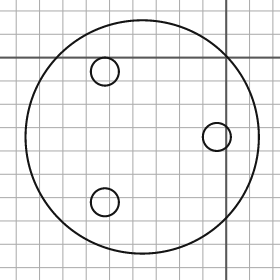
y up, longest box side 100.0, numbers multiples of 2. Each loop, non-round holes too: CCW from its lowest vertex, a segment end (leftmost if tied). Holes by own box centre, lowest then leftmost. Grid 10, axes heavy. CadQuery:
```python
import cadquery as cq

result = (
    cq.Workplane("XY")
    .moveTo(-36.0, -34.0)
    .circle(50.0)
    .moveTo(-52.0, -62.0)
    .circle(6.0)
    .moveTo(-4.0, -34.0)
    .circle(6.0)
    .moveTo(-52.0, -6.0)
    .circle(6.0)
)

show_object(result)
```